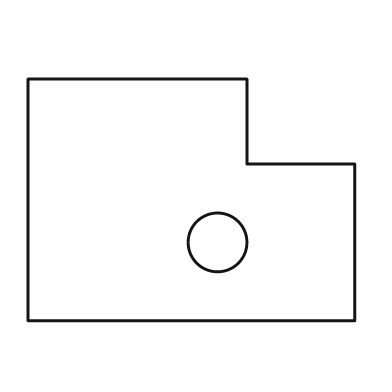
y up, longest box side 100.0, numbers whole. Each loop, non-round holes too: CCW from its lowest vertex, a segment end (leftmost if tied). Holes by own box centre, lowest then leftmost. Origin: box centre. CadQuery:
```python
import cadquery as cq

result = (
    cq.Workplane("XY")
    .moveTo(-50.0, -37.0)
    .lineTo(50.0, -37.0)
    .lineTo(50.0, 11.0)
    .lineTo(17.0, 11.0)
    .lineTo(17.0, 37.0)
    .lineTo(-50.0, 37.0)
    .close()
    .moveTo(8.0, -13.0)
    .circle(9.0)
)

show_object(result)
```